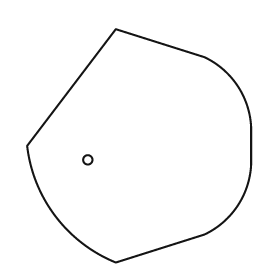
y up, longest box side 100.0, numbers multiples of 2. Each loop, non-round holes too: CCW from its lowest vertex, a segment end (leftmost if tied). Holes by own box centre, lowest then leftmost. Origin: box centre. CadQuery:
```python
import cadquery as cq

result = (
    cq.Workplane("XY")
    .moveTo(-10.0, -50.0)
    .lineTo(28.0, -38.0)
    .threePointArc((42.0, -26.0), (48.0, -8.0))
    .lineTo(48.0, 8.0)
    .threePointArc((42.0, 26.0), (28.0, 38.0))
    .lineTo(-10.0, 50.0)
    .lineTo(-48.0, 0.0)
    .threePointArc((-36.0, -30.0), (-10.0, -50.0))
    .close()
    .moveTo(-22.0, -6.0)
    .circle(2.0)
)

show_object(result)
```